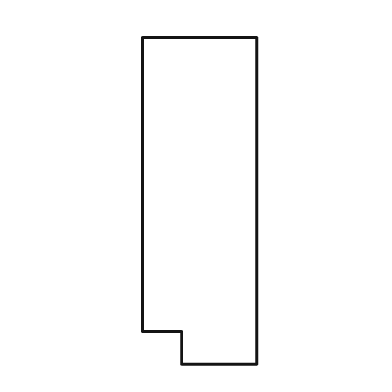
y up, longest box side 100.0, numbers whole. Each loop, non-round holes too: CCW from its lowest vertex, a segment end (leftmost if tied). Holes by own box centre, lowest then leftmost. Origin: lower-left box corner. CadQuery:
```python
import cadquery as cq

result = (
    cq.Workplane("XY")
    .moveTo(12.0, 0.0)
    .lineTo(35.0, 0.0)
    .lineTo(35.0, 100.0)
    .lineTo(0.0, 100.0)
    .lineTo(0.0, 10.0)
    .lineTo(12.0, 10.0)
    .close()
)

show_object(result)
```